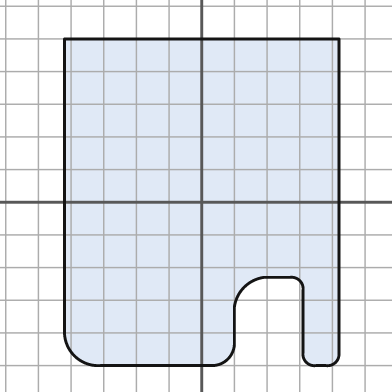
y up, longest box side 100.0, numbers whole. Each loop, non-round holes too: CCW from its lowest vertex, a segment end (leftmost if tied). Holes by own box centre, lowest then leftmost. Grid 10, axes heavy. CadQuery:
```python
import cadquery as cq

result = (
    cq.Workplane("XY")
    .moveTo(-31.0, -50.0)
    .lineTo(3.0, -50.0)
    .threePointArc((8.0, -48.0), (10.0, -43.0))
    .lineTo(10.0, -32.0)
    .threePointArc((13.0, -26.0), (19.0, -23.0))
    .lineTo(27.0, -23.0)
    .threePointArc((30.0, -24.0), (31.0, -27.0))
    .lineTo(31.0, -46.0)
    .threePointArc((32.0, -49.0), (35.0, -50.0))
    .lineTo(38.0, -50.0)
    .threePointArc((41.0, -49.0), (42.0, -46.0))
    .lineTo(42.0, 50.0)
    .lineTo(-42.0, 50.0)
    .lineTo(-42.0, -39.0)
    .threePointArc((-39.0, -47.0), (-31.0, -50.0))
    .close()
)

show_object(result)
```